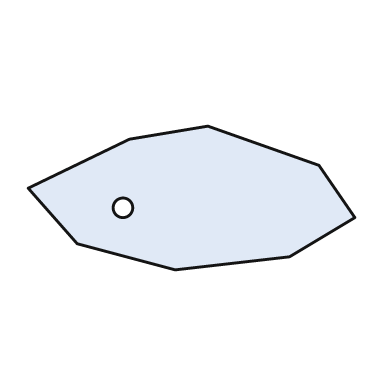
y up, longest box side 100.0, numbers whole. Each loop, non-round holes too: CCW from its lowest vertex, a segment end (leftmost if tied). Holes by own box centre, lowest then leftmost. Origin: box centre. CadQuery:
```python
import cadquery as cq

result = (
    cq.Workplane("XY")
    .moveTo(-5.0, -22.0)
    .lineTo(30.0, -18.0)
    .lineTo(50.0, -6.0)
    .lineTo(39.0, 10.0)
    .lineTo(5.0, 22.0)
    .lineTo(-19.0, 18.0)
    .lineTo(-50.0, 3.0)
    .lineTo(-35.0, -14.0)
    .close()
    .moveTo(-21.0, -3.0)
    .circle(3.0)
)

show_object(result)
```